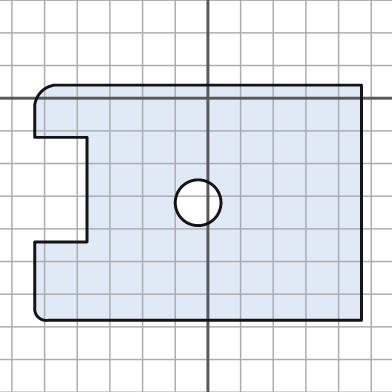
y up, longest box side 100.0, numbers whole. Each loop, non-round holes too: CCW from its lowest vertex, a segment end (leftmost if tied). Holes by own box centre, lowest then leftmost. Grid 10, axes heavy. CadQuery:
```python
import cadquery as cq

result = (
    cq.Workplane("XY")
    .moveTo(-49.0, -68.0)
    .lineTo(47.0, -68.0)
    .lineTo(47.0, 4.0)
    .lineTo(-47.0, 4.0)
    .threePointArc((-51.0, 2.0), (-53.0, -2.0))
    .lineTo(-53.0, -12.0)
    .lineTo(-37.0, -12.0)
    .lineTo(-37.0, -44.0)
    .lineTo(-53.0, -44.0)
    .lineTo(-53.0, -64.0)
    .threePointArc((-52.0, -67.0), (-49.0, -68.0))
    .close()
    .moveTo(-3.0, -32.0)
    .circle(7.0)
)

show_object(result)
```